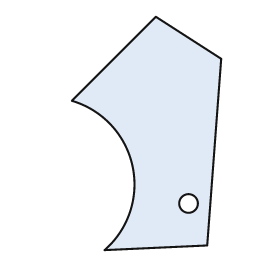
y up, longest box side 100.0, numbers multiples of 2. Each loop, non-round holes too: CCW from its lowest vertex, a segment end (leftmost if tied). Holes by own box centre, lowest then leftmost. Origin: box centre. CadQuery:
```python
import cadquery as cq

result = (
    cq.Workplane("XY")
    .moveTo(-18.0, -50.0)
    .lineTo(26.0, -48.0)
    .lineTo(32.0, 32.0)
    .lineTo(4.0, 50.0)
    .lineTo(-32.0, 14.0)
    .threePointArc((-6.0, -14.0), (-18.0, -50.0))
    .close()
    .moveTo(18.0, -30.0)
    .circle(4.0)
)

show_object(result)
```